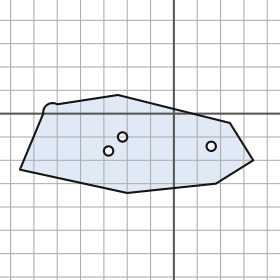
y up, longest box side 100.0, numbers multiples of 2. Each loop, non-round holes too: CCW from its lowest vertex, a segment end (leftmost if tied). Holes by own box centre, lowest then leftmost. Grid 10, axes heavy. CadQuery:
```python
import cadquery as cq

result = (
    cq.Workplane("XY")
    .moveTo(-20.0, -34.0)
    .lineTo(18.0, -30.0)
    .lineTo(34.0, -20.0)
    .lineTo(24.0, -4.0)
    .lineTo(-24.0, 8.0)
    .lineTo(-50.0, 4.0)
    .threePointArc((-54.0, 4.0), (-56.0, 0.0))
    .lineTo(-66.0, -24.0)
    .close()
    .moveTo(-28.0, -16.0)
    .circle(2.0)
    .moveTo(16.0, -14.0)
    .circle(2.0)
    .moveTo(-22.0, -10.0)
    .circle(2.0)
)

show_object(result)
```